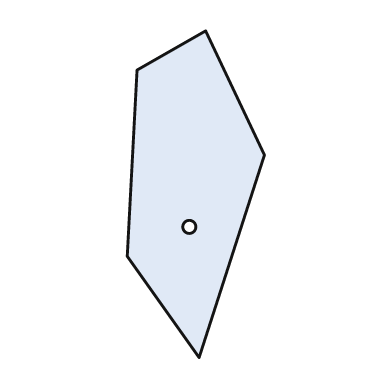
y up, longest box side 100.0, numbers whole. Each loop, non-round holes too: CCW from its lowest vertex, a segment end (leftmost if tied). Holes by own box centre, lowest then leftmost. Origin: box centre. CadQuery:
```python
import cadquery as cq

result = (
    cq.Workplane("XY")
    .moveTo(1.0, -50.0)
    .lineTo(21.0, 12.0)
    .lineTo(3.0, 50.0)
    .lineTo(-18.0, 38.0)
    .lineTo(-21.0, -19.0)
    .close()
    .moveTo(-2.0, -10.0)
    .circle(2.0)
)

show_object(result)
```